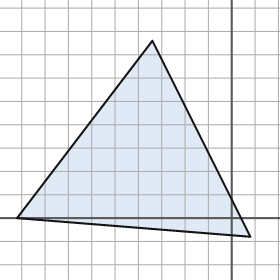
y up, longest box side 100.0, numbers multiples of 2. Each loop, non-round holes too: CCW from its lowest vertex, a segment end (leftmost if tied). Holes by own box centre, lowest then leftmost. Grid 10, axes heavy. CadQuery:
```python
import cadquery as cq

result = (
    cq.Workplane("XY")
    .moveTo(8.0, -8.0)
    .lineTo(-34.0, 76.0)
    .lineTo(-92.0, 0.0)
    .close()
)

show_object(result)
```